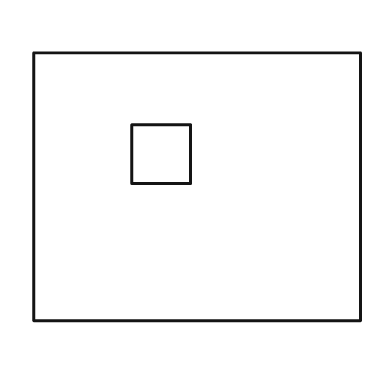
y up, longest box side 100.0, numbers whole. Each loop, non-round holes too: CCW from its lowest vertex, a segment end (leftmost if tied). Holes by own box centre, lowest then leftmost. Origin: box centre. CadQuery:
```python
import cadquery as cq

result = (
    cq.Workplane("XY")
    .moveTo(-50.0, -41.0)
    .lineTo(50.0, -41.0)
    .lineTo(50.0, 41.0)
    .lineTo(-50.0, 41.0)
    .close()
    .moveTo(-20.0, 1.0)
    .lineTo(-2.0, 1.0)
    .lineTo(-2.0, 19.0)
    .lineTo(-20.0, 19.0)
    .close()
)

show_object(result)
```